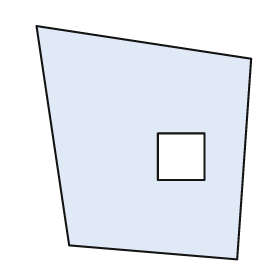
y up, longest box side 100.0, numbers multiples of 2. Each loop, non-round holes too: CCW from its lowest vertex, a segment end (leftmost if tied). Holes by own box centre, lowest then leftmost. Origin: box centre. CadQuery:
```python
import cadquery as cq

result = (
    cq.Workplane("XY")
    .moveTo(40.0, -50.0)
    .lineTo(46.0, 36.0)
    .lineTo(-46.0, 50.0)
    .lineTo(-32.0, -44.0)
    .close()
    .moveTo(6.0, -16.0)
    .lineTo(26.0, -16.0)
    .lineTo(26.0, 4.0)
    .lineTo(6.0, 4.0)
    .close()
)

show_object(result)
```